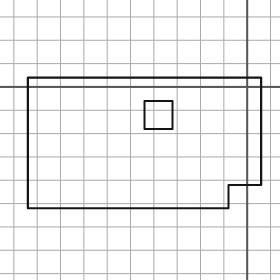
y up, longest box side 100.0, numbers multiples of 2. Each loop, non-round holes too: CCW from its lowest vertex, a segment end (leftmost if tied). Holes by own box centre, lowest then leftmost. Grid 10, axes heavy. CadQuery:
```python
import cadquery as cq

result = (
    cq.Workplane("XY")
    .moveTo(-94.0, -52.0)
    .lineTo(-8.0, -52.0)
    .lineTo(-8.0, -42.0)
    .lineTo(6.0, -42.0)
    .lineTo(6.0, 4.0)
    .lineTo(-94.0, 4.0)
    .close()
    .moveTo(-44.0, -18.0)
    .lineTo(-32.0, -18.0)
    .lineTo(-32.0, -6.0)
    .lineTo(-44.0, -6.0)
    .close()
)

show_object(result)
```